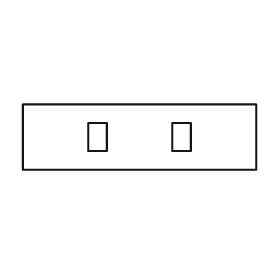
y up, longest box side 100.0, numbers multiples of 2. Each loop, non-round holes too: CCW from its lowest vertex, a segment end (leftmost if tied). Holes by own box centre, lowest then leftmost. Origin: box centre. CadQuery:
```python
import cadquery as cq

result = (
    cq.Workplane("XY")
    .moveTo(-50.0, -14.0)
    .lineTo(50.0, -14.0)
    .lineTo(50.0, 14.0)
    .lineTo(-50.0, 14.0)
    .close()
    .moveTo(-22.0, -6.0)
    .lineTo(-14.0, -6.0)
    .lineTo(-14.0, 6.0)
    .lineTo(-22.0, 6.0)
    .close()
    .moveTo(14.0, -6.0)
    .lineTo(22.0, -6.0)
    .lineTo(22.0, 6.0)
    .lineTo(14.0, 6.0)
    .close()
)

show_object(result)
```